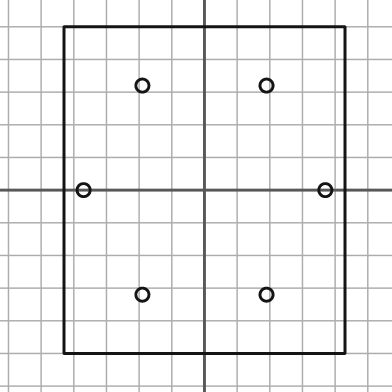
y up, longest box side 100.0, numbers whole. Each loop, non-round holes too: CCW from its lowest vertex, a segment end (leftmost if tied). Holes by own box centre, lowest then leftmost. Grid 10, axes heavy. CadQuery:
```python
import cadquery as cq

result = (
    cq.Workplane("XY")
    .moveTo(-43.0, -50.0)
    .lineTo(43.0, -50.0)
    .lineTo(43.0, 50.0)
    .lineTo(-43.0, 50.0)
    .close()
    .moveTo(-19.0, -32.0)
    .circle(2.0)
    .moveTo(19.0, -32.0)
    .circle(2.0)
    .moveTo(-37.0, 0.0)
    .circle(2.0)
    .moveTo(37.0, 0.0)
    .circle(2.0)
    .moveTo(-19.0, 32.0)
    .circle(2.0)
    .moveTo(19.0, 32.0)
    .circle(2.0)
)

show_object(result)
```